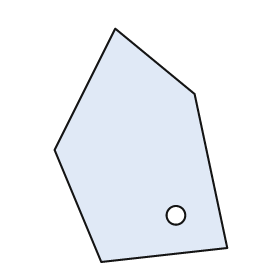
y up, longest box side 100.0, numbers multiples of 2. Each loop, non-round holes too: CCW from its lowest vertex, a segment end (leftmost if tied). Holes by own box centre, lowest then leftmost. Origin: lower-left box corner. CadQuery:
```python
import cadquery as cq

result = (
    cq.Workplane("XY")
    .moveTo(20.0, 0.0)
    .lineTo(74.0, 6.0)
    .lineTo(60.0, 72.0)
    .lineTo(26.0, 100.0)
    .lineTo(0.0, 48.0)
    .close()
    .moveTo(52.0, 20.0)
    .circle(4.0)
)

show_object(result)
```